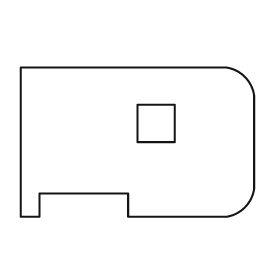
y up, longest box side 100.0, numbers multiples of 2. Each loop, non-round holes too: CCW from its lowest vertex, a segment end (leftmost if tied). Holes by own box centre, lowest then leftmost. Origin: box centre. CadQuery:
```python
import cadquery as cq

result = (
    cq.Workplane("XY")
    .moveTo(-50.0, -32.0)
    .lineTo(-42.0, -32.0)
    .lineTo(-42.0, -22.0)
    .lineTo(-4.0, -22.0)
    .lineTo(-4.0, -32.0)
    .lineTo(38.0, -32.0)
    .threePointArc((46.0, -28.0), (50.0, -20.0))
    .lineTo(50.0, 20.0)
    .threePointArc((46.0, 28.0), (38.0, 32.0))
    .lineTo(-50.0, 32.0)
    .close()
    .moveTo(0.0, 0.0)
    .lineTo(16.0, 0.0)
    .lineTo(16.0, 16.0)
    .lineTo(0.0, 16.0)
    .close()
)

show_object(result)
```